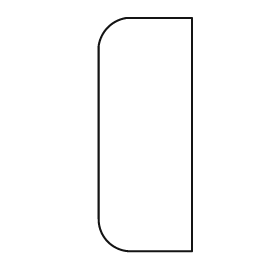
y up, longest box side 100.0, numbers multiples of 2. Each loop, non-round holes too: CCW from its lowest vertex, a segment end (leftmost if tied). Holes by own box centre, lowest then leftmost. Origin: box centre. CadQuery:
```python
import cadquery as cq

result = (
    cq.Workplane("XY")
    .moveTo(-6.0, -50.0)
    .lineTo(20.0, -50.0)
    .lineTo(20.0, 50.0)
    .lineTo(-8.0, 50.0)
    .threePointArc((-16.0, 46.0), (-20.0, 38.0))
    .lineTo(-20.0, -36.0)
    .threePointArc((-16.0, -46.0), (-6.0, -50.0))
    .close()
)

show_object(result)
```